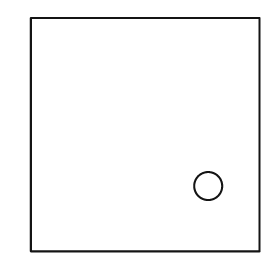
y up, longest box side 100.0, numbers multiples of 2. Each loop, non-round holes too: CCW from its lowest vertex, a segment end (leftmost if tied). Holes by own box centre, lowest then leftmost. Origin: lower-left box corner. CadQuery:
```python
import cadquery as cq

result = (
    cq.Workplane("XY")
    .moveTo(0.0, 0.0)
    .lineTo(98.0, 0.0)
    .lineTo(98.0, 100.0)
    .lineTo(0.0, 100.0)
    .close()
    .moveTo(76.0, 28.0)
    .circle(6.0)
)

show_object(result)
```